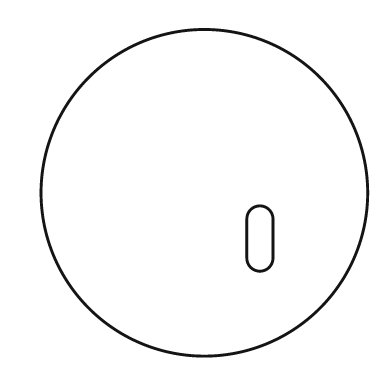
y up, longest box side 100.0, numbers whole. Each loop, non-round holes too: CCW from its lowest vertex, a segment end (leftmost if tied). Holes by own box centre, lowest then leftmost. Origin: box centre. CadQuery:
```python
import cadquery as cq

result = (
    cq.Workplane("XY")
    .moveTo(0.0, 0.0)
    .circle(50.0)
    .moveTo(13.0, -20.0)
    .threePointArc((17.0, -24.0), (21.0, -20.0))
    .lineTo(21.0, -8.0)
    .threePointArc((17.0, -4.0), (13.0, -8.0))
    .close()
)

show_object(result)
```